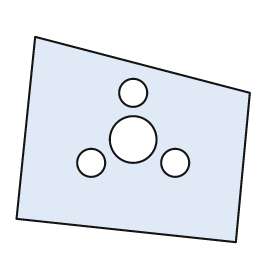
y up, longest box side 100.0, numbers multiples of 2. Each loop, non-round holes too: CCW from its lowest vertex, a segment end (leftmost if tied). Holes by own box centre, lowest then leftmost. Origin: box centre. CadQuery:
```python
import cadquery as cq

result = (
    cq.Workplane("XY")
    .moveTo(44.0, -44.0)
    .lineTo(50.0, 20.0)
    .lineTo(-42.0, 44.0)
    .lineTo(-50.0, -34.0)
    .close()
    .moveTo(-18.0, -10.0)
    .circle(6.0)
    .moveTo(18.0, -10.0)
    .circle(6.0)
    .moveTo(0.0, 0.0)
    .circle(10.0)
    .moveTo(0.0, 20.0)
    .circle(6.0)
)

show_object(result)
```